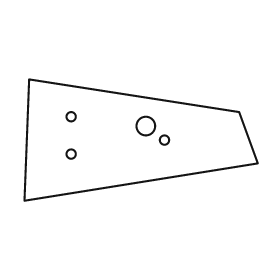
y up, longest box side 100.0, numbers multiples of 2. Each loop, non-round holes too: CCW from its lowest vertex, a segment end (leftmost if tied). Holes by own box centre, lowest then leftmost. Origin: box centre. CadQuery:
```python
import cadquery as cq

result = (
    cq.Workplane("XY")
    .moveTo(-50.0, -26.0)
    .lineTo(50.0, -10.0)
    .lineTo(42.0, 12.0)
    .lineTo(-48.0, 26.0)
    .close()
    .moveTo(-30.0, -6.0)
    .circle(2.0)
    .moveTo(10.0, 0.0)
    .circle(2.0)
    .moveTo(2.0, 6.0)
    .circle(4.0)
    .moveTo(-30.0, 10.0)
    .circle(2.0)
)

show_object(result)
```